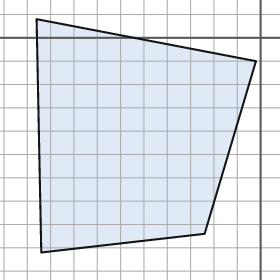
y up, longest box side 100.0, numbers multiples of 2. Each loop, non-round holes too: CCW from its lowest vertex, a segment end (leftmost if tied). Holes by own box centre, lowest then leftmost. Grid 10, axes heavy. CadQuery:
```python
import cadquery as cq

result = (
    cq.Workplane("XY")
    .moveTo(-94.0, -92.0)
    .lineTo(-24.0, -84.0)
    .lineTo(-2.0, -10.0)
    .lineTo(-96.0, 8.0)
    .close()
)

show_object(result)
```